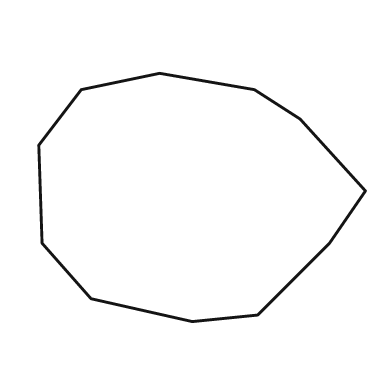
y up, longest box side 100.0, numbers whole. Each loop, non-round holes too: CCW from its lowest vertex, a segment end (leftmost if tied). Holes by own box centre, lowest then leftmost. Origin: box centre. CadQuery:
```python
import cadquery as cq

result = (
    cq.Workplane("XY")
    .moveTo(-3.0, -38.0)
    .lineTo(17.0, -36.0)
    .lineTo(39.0, -14.0)
    .lineTo(50.0, 2.0)
    .lineTo(30.0, 24.0)
    .lineTo(16.0, 33.0)
    .lineTo(-13.0, 38.0)
    .lineTo(-37.0, 33.0)
    .lineTo(-50.0, 16.0)
    .lineTo(-49.0, -14.0)
    .lineTo(-34.0, -31.0)
    .close()
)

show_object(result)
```